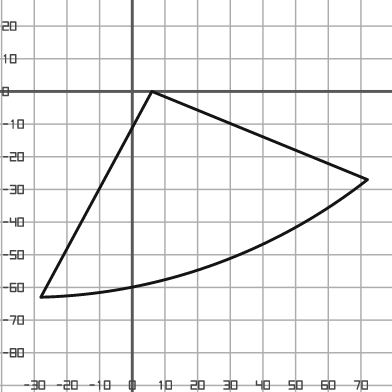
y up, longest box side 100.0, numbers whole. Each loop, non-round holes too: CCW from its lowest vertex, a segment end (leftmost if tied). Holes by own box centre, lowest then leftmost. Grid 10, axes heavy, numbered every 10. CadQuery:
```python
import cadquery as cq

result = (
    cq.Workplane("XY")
    .moveTo(-28.0, -63.0)
    .threePointArc((25.0, -53.0), (72.0, -27.0))
    .lineTo(6.0, 0.0)
    .close()
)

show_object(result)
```